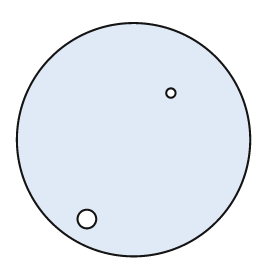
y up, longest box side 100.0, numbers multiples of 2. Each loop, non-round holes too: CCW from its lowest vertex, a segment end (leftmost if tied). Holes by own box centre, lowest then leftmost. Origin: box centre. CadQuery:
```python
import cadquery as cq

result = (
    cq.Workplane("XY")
    .moveTo(0.0, 0.0)
    .circle(50.0)
    .moveTo(-20.0, -34.0)
    .circle(4.0)
    .moveTo(16.0, 20.0)
    .circle(2.0)
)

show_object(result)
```